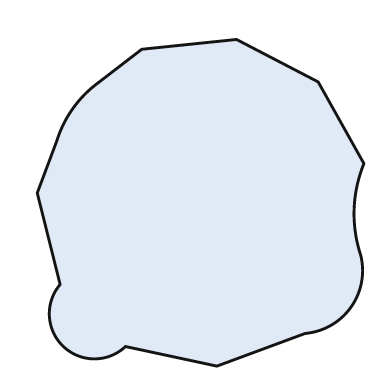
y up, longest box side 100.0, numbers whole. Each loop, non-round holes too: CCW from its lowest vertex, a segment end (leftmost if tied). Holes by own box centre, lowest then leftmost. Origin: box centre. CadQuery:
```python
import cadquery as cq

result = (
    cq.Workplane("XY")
    .moveTo(5.0, -50.0)
    .lineTo(32.0, -40.0)
    .threePointArc((46.0, -32.0), (49.0, -16.0))
    .threePointArc((47.0, -2.0), (50.0, 12.0))
    .lineTo(36.0, 37.0)
    .lineTo(11.0, 50.0)
    .lineTo(-18.0, 47.0)
    .lineTo(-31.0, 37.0)
    .threePointArc((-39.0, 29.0), (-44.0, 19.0))
    .lineTo(-50.0, 3.0)
    .lineTo(-43.0, -25.0)
    .threePointArc((-42.0, -44.0), (-23.0, -44.0))
    .close()
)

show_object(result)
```